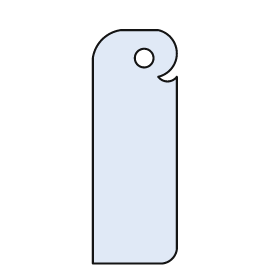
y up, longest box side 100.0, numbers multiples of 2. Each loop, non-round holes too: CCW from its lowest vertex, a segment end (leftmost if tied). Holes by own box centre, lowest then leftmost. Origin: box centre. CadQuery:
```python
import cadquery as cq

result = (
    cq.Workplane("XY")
    .moveTo(-18.0, -50.0)
    .lineTo(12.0, -50.0)
    .threePointArc((16.0, -48.0), (18.0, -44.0))
    .lineTo(18.0, 30.0)
    .threePointArc((14.0, 28.0), (10.0, 30.0))
    .threePointArc((18.0, 40.0), (10.0, 50.0))
    .lineTo(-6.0, 50.0)
    .threePointArc((-14.0, 46.0), (-18.0, 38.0))
    .close()
    .moveTo(4.0, 38.0)
    .circle(4.0)
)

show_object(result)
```